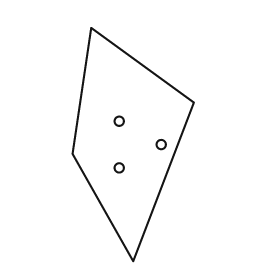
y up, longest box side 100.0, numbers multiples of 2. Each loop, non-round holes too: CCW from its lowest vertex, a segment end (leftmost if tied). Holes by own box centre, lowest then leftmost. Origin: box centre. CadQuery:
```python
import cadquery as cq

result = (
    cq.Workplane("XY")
    .moveTo(0.0, -50.0)
    .lineTo(26.0, 18.0)
    .lineTo(-18.0, 50.0)
    .lineTo(-26.0, -4.0)
    .close()
    .moveTo(-6.0, -10.0)
    .circle(2.0)
    .moveTo(12.0, 0.0)
    .circle(2.0)
    .moveTo(-6.0, 10.0)
    .circle(2.0)
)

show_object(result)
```